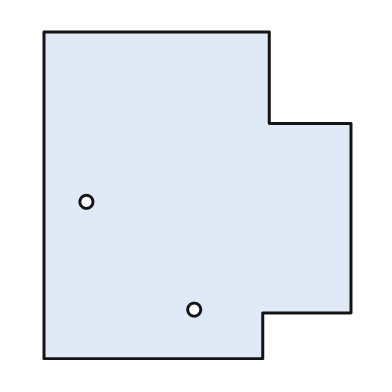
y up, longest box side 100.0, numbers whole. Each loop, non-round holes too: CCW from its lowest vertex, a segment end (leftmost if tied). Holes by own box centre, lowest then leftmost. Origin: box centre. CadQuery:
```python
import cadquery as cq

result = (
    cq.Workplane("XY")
    .moveTo(-47.0, -50.0)
    .lineTo(20.0, -50.0)
    .lineTo(20.0, -36.0)
    .lineTo(47.0, -36.0)
    .lineTo(47.0, 22.0)
    .lineTo(22.0, 22.0)
    .lineTo(22.0, 50.0)
    .lineTo(-47.0, 50.0)
    .close()
    .moveTo(-1.0, -35.0)
    .circle(2.0)
    .moveTo(-34.0, -2.0)
    .circle(2.0)
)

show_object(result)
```